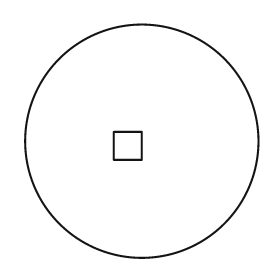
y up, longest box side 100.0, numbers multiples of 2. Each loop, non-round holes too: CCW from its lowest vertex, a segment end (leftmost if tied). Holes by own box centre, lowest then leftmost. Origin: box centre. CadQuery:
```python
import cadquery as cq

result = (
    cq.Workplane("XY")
    .moveTo(0.0, 0.0)
    .circle(50.0)
    .moveTo(-12.0, -8.0)
    .lineTo(0.0, -8.0)
    .lineTo(0.0, 4.0)
    .lineTo(-12.0, 4.0)
    .close()
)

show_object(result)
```